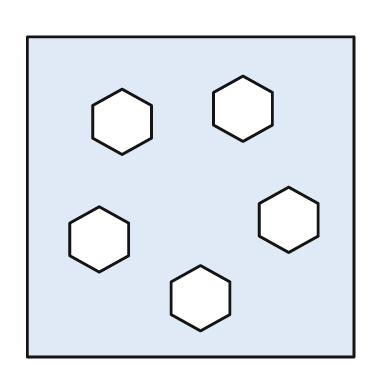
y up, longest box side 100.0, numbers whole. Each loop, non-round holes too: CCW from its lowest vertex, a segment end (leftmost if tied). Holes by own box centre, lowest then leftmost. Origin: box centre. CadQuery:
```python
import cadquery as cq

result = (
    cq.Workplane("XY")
    .moveTo(-50.0, -49.0)
    .lineTo(50.0, -49.0)
    .lineTo(50.0, 49.0)
    .lineTo(-50.0, 49.0)
    .close()
    .moveTo(3.0, -41.0)
    .lineTo(12.0, -36.0)
    .lineTo(12.0, -26.0)
    .lineTo(3.0, -21.0)
    .lineTo(-6.0, -26.0)
    .lineTo(-6.0, -36.0)
    .close()
    .moveTo(-28.0, -23.0)
    .lineTo(-19.0, -18.0)
    .lineTo(-19.0, -8.0)
    .lineTo(-28.0, -3.0)
    .lineTo(-37.0, -8.0)
    .lineTo(-37.0, -18.0)
    .close()
    .moveTo(30.0, -17.0)
    .lineTo(39.0, -12.0)
    .lineTo(39.0, -2.0)
    .lineTo(30.0, 3.0)
    .lineTo(21.0, -2.0)
    .lineTo(21.0, -12.0)
    .close()
    .moveTo(-21.0, 13.0)
    .lineTo(-12.0, 18.0)
    .lineTo(-12.0, 28.0)
    .lineTo(-21.0, 33.0)
    .lineTo(-30.0, 28.0)
    .lineTo(-30.0, 18.0)
    .close()
    .moveTo(16.0, 17.0)
    .lineTo(25.0, 22.0)
    .lineTo(25.0, 32.0)
    .lineTo(16.0, 37.0)
    .lineTo(7.0, 32.0)
    .lineTo(7.0, 22.0)
    .close()
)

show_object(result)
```